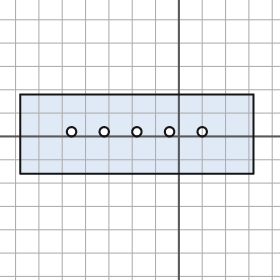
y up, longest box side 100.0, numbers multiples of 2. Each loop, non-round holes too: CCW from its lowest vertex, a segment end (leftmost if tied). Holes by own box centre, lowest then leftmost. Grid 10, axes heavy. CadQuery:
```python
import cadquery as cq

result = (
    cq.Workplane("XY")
    .moveTo(-68.0, -16.0)
    .lineTo(32.0, -16.0)
    .lineTo(32.0, 18.0)
    .lineTo(-68.0, 18.0)
    .close()
    .moveTo(-46.0, 2.0)
    .circle(2.0)
    .moveTo(-32.0, 2.0)
    .circle(2.0)
    .moveTo(-18.0, 2.0)
    .circle(2.0)
    .moveTo(-4.0, 2.0)
    .circle(2.0)
    .moveTo(10.0, 2.0)
    .circle(2.0)
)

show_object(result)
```